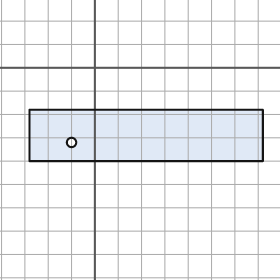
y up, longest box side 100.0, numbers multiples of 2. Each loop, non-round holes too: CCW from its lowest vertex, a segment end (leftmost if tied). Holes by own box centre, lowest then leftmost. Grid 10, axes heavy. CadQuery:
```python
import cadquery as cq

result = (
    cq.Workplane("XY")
    .moveTo(-28.0, -40.0)
    .lineTo(72.0, -40.0)
    .lineTo(72.0, -18.0)
    .lineTo(-28.0, -18.0)
    .close()
    .moveTo(-10.0, -32.0)
    .circle(2.0)
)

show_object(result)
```